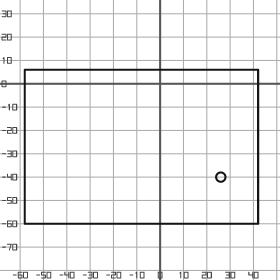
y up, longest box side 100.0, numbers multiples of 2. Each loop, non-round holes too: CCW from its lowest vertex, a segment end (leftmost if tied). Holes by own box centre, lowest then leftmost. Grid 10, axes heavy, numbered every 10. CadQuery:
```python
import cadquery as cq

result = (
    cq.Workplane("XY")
    .moveTo(-58.0, -60.0)
    .lineTo(42.0, -60.0)
    .lineTo(42.0, 6.0)
    .lineTo(-58.0, 6.0)
    .close()
    .moveTo(26.0, -40.0)
    .circle(2.0)
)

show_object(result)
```